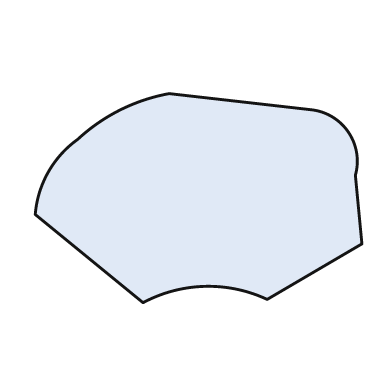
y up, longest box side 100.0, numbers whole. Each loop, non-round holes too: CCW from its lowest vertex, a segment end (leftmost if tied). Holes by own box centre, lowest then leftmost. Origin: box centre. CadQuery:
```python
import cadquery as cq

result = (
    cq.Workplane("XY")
    .moveTo(-17.0, -32.0)
    .threePointArc((2.0, -27.0), (21.0, -31.0))
    .lineTo(50.0, -14.0)
    .lineTo(48.0, 7.0)
    .threePointArc((46.0, 20.0), (35.0, 27.0))
    .lineTo(-9.0, 32.0)
    .threePointArc((-24.0, 27.0), (-37.0, 18.0))
    .threePointArc((-46.0, 8.0), (-50.0, -5.0))
    .close()
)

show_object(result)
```